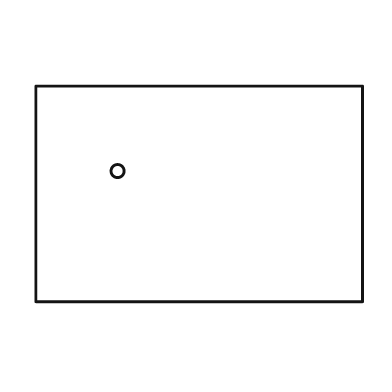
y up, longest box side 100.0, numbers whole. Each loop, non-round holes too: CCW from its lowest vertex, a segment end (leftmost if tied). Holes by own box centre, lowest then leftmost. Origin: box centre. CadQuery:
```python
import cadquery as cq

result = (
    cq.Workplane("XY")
    .moveTo(-50.0, -33.0)
    .lineTo(50.0, -33.0)
    .lineTo(50.0, 33.0)
    .lineTo(-50.0, 33.0)
    .close()
    .moveTo(-25.0, 7.0)
    .circle(2.0)
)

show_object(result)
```